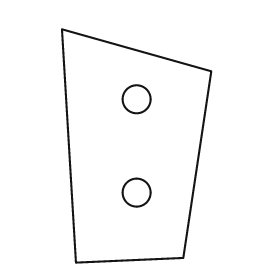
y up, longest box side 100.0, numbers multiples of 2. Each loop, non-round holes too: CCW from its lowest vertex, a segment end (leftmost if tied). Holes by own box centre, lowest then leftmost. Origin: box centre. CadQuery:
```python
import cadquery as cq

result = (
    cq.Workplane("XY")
    .moveTo(-26.0, -50.0)
    .lineTo(20.0, -48.0)
    .lineTo(32.0, 32.0)
    .lineTo(-32.0, 50.0)
    .close()
    .moveTo(0.0, -20.0)
    .circle(6.0)
    .moveTo(0.0, 20.0)
    .circle(6.0)
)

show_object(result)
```